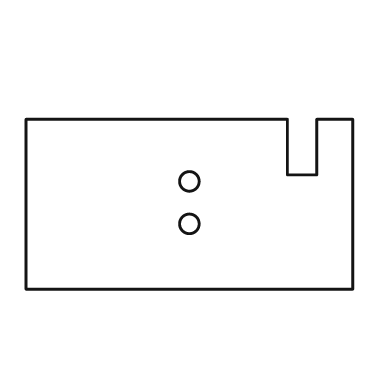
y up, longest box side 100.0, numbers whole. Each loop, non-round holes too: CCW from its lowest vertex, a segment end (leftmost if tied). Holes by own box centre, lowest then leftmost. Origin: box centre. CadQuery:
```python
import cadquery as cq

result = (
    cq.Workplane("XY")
    .moveTo(-50.0, -26.0)
    .lineTo(50.0, -26.0)
    .lineTo(50.0, 26.0)
    .lineTo(39.0, 26.0)
    .lineTo(39.0, 9.0)
    .lineTo(30.0, 9.0)
    .lineTo(30.0, 26.0)
    .lineTo(-50.0, 26.0)
    .close()
    .moveTo(0.0, -6.0)
    .circle(3.0)
    .moveTo(0.0, 7.0)
    .circle(3.0)
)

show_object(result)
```